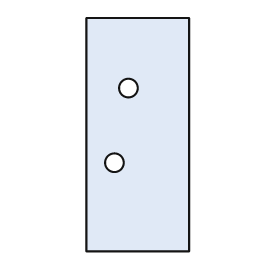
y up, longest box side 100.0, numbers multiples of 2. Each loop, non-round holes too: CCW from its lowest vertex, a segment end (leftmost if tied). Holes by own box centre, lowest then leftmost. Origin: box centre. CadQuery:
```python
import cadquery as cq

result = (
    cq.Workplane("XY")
    .moveTo(-22.0, -50.0)
    .lineTo(22.0, -50.0)
    .lineTo(22.0, 50.0)
    .lineTo(-22.0, 50.0)
    .close()
    .moveTo(-10.0, -12.0)
    .circle(4.0)
    .moveTo(-4.0, 20.0)
    .circle(4.0)
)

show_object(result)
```